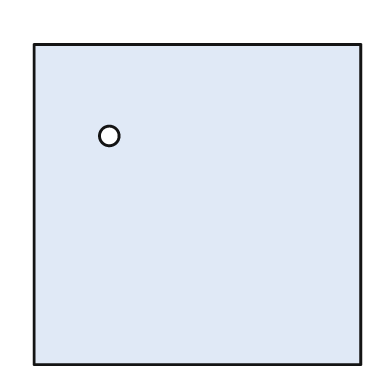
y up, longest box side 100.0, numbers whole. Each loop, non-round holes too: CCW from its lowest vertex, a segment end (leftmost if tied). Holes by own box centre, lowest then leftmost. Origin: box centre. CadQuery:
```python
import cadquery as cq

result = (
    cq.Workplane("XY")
    .moveTo(-50.0, -49.0)
    .lineTo(50.0, -49.0)
    .lineTo(50.0, 49.0)
    .lineTo(-50.0, 49.0)
    .close()
    .moveTo(-27.0, 21.0)
    .circle(3.0)
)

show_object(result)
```